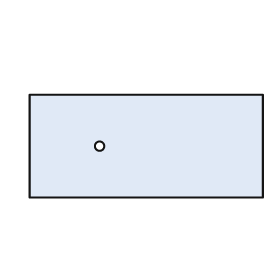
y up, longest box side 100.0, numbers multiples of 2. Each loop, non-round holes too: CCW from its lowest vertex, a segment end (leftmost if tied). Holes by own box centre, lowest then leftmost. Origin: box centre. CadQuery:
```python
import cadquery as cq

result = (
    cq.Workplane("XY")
    .moveTo(-50.0, -22.0)
    .lineTo(50.0, -22.0)
    .lineTo(50.0, 22.0)
    .lineTo(-50.0, 22.0)
    .close()
    .moveTo(-20.0, 0.0)
    .circle(2.0)
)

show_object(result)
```